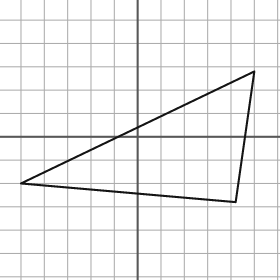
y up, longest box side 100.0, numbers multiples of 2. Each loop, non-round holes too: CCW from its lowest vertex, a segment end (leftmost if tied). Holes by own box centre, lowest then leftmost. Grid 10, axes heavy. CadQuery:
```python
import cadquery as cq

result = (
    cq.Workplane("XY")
    .moveTo(42.0, -28.0)
    .lineTo(50.0, 28.0)
    .lineTo(-50.0, -20.0)
    .close()
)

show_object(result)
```